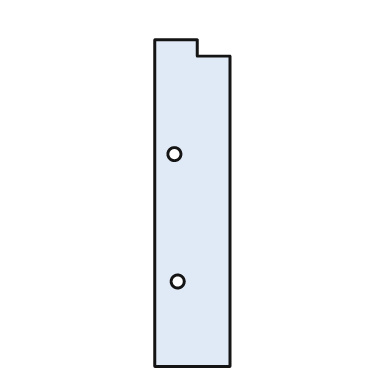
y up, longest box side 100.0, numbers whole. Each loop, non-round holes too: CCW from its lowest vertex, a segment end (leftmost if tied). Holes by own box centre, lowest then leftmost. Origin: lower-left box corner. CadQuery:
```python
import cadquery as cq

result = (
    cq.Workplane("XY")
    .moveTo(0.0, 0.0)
    .lineTo(23.0, 0.0)
    .lineTo(23.0, 95.0)
    .lineTo(13.0, 95.0)
    .lineTo(13.0, 100.0)
    .lineTo(0.0, 100.0)
    .close()
    .moveTo(7.0, 26.0)
    .circle(2.0)
    .moveTo(6.0, 65.0)
    .circle(2.0)
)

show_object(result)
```